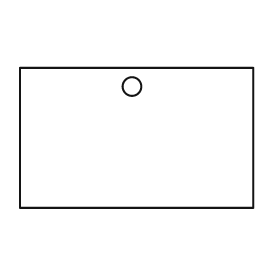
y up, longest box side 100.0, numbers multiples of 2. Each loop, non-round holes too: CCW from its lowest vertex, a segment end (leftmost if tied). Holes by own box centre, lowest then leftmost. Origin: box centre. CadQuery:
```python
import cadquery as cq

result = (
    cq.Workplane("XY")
    .moveTo(-50.0, -30.0)
    .lineTo(50.0, -30.0)
    .lineTo(50.0, 30.0)
    .lineTo(-50.0, 30.0)
    .close()
    .moveTo(-2.0, 22.0)
    .circle(4.0)
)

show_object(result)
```